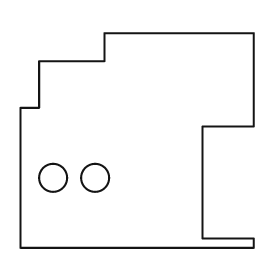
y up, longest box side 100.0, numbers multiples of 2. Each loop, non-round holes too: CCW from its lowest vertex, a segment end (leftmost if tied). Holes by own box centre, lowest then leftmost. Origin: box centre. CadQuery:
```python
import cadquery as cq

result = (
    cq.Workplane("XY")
    .moveTo(-50.0, -46.0)
    .lineTo(50.0, -46.0)
    .lineTo(50.0, -42.0)
    .lineTo(28.0, -42.0)
    .lineTo(28.0, 6.0)
    .lineTo(50.0, 6.0)
    .lineTo(50.0, 46.0)
    .lineTo(-14.0, 46.0)
    .lineTo(-14.0, 34.0)
    .lineTo(-42.0, 34.0)
    .lineTo(-42.0, 14.0)
    .lineTo(-50.0, 14.0)
    .close()
    .moveTo(-36.0, -16.0)
    .circle(6.0)
    .moveTo(-18.0, -16.0)
    .circle(6.0)
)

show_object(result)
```